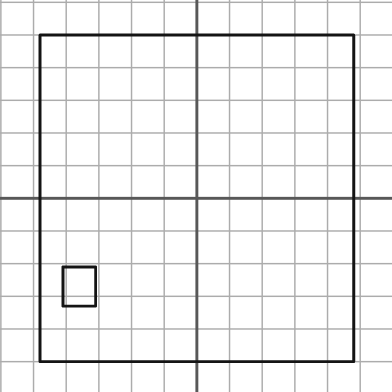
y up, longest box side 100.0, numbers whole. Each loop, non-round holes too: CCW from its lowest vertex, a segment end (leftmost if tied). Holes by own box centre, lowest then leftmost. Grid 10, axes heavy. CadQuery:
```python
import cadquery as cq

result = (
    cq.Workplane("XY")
    .moveTo(-48.0, -50.0)
    .lineTo(48.0, -50.0)
    .lineTo(48.0, 50.0)
    .lineTo(-48.0, 50.0)
    .close()
    .moveTo(-41.0, -33.0)
    .lineTo(-31.0, -33.0)
    .lineTo(-31.0, -21.0)
    .lineTo(-41.0, -21.0)
    .close()
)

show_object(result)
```